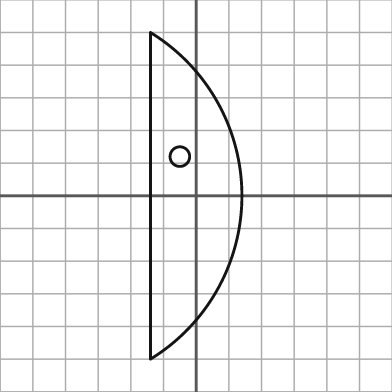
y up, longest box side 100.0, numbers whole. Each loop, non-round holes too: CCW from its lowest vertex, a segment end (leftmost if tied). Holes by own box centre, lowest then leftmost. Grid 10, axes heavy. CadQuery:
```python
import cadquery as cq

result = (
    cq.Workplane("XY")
    .moveTo(-14.0, -50.0)
    .threePointArc((14.0, 0.0), (-14.0, 50.0))
    .close()
    .moveTo(-5.0, 12.0)
    .circle(3.0)
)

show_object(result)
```